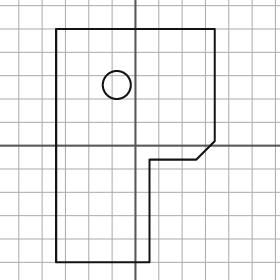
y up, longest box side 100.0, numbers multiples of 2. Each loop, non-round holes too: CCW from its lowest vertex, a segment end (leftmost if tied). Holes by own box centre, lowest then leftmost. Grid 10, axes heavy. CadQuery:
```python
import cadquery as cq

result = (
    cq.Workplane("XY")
    .moveTo(-34.0, -50.0)
    .lineTo(6.0, -50.0)
    .lineTo(6.0, -6.0)
    .lineTo(26.0, -6.0)
    .lineTo(34.0, 2.0)
    .lineTo(34.0, 50.0)
    .lineTo(-34.0, 50.0)
    .close()
    .moveTo(-8.0, 26.0)
    .circle(6.0)
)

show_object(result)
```